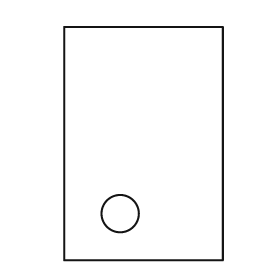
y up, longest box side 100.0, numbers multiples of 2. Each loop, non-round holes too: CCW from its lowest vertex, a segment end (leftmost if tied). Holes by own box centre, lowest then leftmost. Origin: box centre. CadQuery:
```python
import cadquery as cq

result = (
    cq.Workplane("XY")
    .moveTo(-34.0, -50.0)
    .lineTo(34.0, -50.0)
    .lineTo(34.0, 50.0)
    .lineTo(-34.0, 50.0)
    .close()
    .moveTo(-10.0, -30.0)
    .circle(8.0)
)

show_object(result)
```